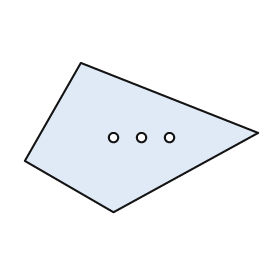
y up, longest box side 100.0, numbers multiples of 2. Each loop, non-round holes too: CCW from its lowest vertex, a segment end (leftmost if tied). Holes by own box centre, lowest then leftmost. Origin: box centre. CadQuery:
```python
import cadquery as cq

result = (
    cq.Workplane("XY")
    .moveTo(-12.0, -32.0)
    .lineTo(50.0, 2.0)
    .lineTo(-26.0, 32.0)
    .lineTo(-50.0, -10.0)
    .close()
    .moveTo(-12.0, 0.0)
    .circle(2.0)
    .moveTo(0.0, 0.0)
    .circle(2.0)
    .moveTo(12.0, 0.0)
    .circle(2.0)
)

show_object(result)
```